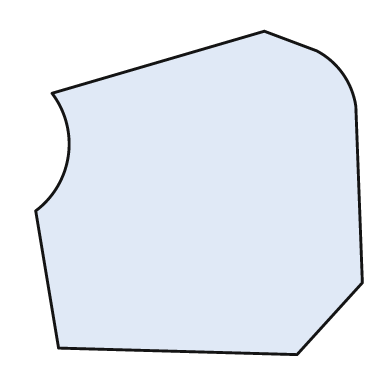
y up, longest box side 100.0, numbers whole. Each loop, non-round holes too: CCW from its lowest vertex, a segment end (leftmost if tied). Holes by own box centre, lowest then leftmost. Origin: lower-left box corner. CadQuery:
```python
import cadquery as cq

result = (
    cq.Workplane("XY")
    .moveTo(80.0, 0.0)
    .lineTo(100.0, 22.0)
    .lineTo(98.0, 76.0)
    .threePointArc((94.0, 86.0), (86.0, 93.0))
    .lineTo(70.0, 99.0)
    .lineTo(5.0, 80.0)
    .threePointArc((10.0, 61.0), (0.0, 44.0))
    .lineTo(7.0, 2.0)
    .close()
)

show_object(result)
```